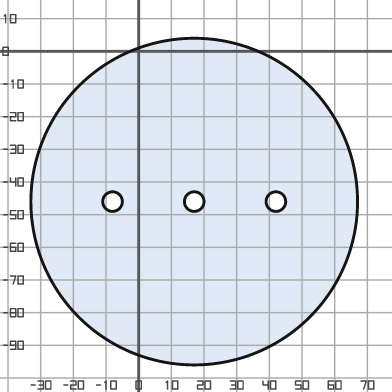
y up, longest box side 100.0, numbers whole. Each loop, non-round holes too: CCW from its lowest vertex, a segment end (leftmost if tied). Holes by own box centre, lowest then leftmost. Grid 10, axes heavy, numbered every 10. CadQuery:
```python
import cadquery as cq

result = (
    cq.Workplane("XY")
    .moveTo(17.0, -46.0)
    .circle(50.0)
    .moveTo(-8.0, -46.0)
    .circle(3.0)
    .moveTo(17.0, -46.0)
    .circle(3.0)
    .moveTo(42.0, -46.0)
    .circle(3.0)
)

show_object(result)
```